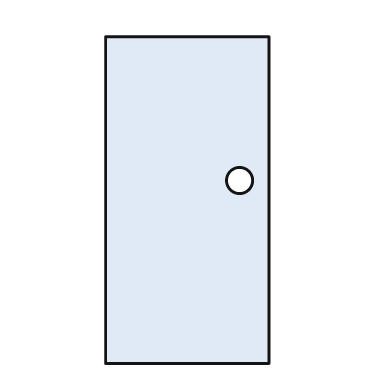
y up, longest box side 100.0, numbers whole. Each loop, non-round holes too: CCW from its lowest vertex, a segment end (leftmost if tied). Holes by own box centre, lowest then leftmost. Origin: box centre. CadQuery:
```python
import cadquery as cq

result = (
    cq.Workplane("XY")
    .moveTo(-25.0, -50.0)
    .lineTo(25.0, -50.0)
    .lineTo(25.0, 50.0)
    .lineTo(-25.0, 50.0)
    .close()
    .moveTo(16.0, 6.0)
    .circle(4.0)
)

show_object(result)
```